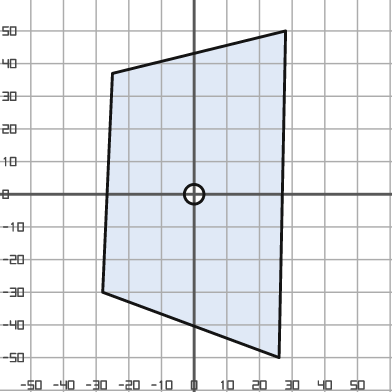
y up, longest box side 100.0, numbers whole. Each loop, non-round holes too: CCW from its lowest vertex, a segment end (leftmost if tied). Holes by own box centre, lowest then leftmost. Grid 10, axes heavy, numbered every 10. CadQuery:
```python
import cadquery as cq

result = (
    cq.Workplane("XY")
    .moveTo(26.0, -50.0)
    .lineTo(28.0, 50.0)
    .lineTo(-25.0, 37.0)
    .lineTo(-28.0, -30.0)
    .close()
    .moveTo(0.0, 0.0)
    .circle(3.0)
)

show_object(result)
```